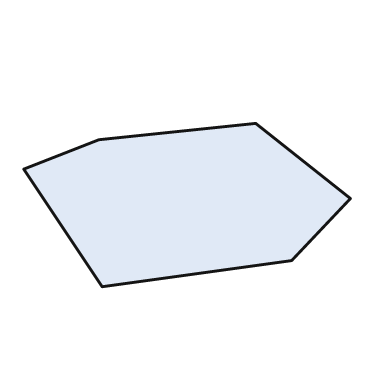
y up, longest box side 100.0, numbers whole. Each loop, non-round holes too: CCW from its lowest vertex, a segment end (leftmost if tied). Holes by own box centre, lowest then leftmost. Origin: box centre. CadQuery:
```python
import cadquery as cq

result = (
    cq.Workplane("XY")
    .moveTo(-26.0, -25.0)
    .lineTo(32.0, -17.0)
    .lineTo(50.0, 2.0)
    .lineTo(21.0, 25.0)
    .lineTo(-27.0, 20.0)
    .lineTo(-50.0, 11.0)
    .close()
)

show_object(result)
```